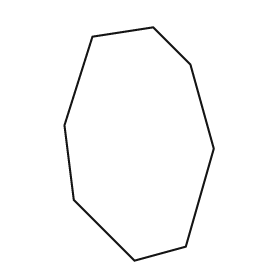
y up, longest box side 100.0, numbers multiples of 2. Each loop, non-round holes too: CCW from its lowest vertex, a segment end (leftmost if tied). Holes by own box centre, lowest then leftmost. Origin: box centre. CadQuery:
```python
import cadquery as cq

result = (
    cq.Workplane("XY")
    .moveTo(-2.0, -50.0)
    .lineTo(20.0, -44.0)
    .lineTo(32.0, -2.0)
    .lineTo(22.0, 34.0)
    .lineTo(6.0, 50.0)
    .lineTo(-20.0, 46.0)
    .lineTo(-32.0, 8.0)
    .lineTo(-28.0, -24.0)
    .close()
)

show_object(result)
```